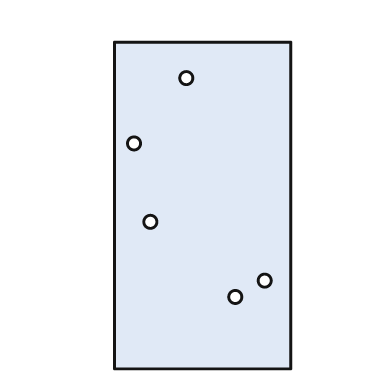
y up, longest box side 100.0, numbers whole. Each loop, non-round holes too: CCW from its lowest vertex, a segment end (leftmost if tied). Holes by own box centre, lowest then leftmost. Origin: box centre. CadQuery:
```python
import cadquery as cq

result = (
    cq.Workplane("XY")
    .moveTo(-27.0, -50.0)
    .lineTo(27.0, -50.0)
    .lineTo(27.0, 50.0)
    .lineTo(-27.0, 50.0)
    .close()
    .moveTo(10.0, -28.0)
    .circle(2.0)
    .moveTo(19.0, -23.0)
    .circle(2.0)
    .moveTo(-16.0, -5.0)
    .circle(2.0)
    .moveTo(-21.0, 19.0)
    .circle(2.0)
    .moveTo(-5.0, 39.0)
    .circle(2.0)
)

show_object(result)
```